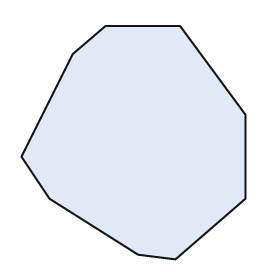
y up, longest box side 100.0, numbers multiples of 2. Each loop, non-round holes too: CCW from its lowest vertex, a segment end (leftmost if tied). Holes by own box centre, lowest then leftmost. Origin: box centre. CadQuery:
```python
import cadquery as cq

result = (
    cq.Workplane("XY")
    .moveTo(18.0, -50.0)
    .lineTo(48.0, -24.0)
    .lineTo(48.0, 12.0)
    .lineTo(20.0, 50.0)
    .lineTo(-12.0, 50.0)
    .lineTo(-26.0, 38.0)
    .lineTo(-48.0, -6.0)
    .lineTo(-36.0, -24.0)
    .lineTo(2.0, -48.0)
    .close()
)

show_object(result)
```